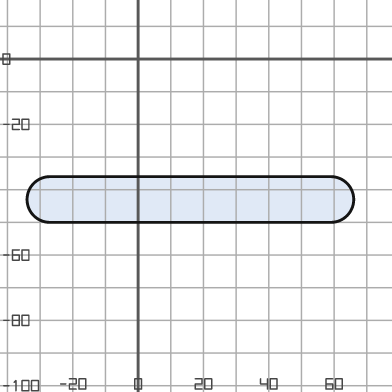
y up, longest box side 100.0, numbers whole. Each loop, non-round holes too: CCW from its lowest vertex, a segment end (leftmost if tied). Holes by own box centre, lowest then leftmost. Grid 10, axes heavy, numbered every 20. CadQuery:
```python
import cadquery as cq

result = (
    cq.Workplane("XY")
    .moveTo(-27.0, -50.0)
    .lineTo(59.0, -50.0)
    .threePointArc((66.0, -43.0), (59.0, -36.0))
    .lineTo(-27.0, -36.0)
    .threePointArc((-34.0, -43.0), (-27.0, -50.0))
    .close()
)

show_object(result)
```